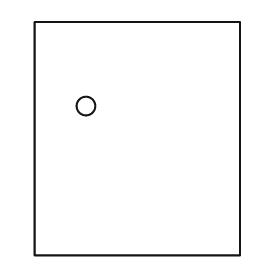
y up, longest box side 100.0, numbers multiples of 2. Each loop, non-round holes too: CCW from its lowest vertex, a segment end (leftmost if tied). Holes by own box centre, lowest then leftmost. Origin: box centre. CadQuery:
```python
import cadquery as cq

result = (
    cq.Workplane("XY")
    .moveTo(-44.0, -50.0)
    .lineTo(44.0, -50.0)
    .lineTo(44.0, 50.0)
    .lineTo(-44.0, 50.0)
    .close()
    .moveTo(-22.0, 14.0)
    .circle(4.0)
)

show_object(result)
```